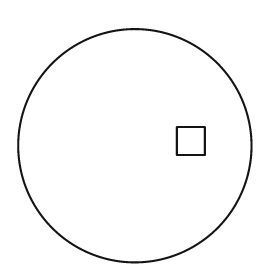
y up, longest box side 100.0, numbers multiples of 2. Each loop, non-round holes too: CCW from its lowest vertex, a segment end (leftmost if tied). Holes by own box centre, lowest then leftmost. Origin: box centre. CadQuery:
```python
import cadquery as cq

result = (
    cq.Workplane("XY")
    .moveTo(0.0, 0.0)
    .circle(50.0)
    .moveTo(18.0, -4.0)
    .lineTo(30.0, -4.0)
    .lineTo(30.0, 8.0)
    .lineTo(18.0, 8.0)
    .close()
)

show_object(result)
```